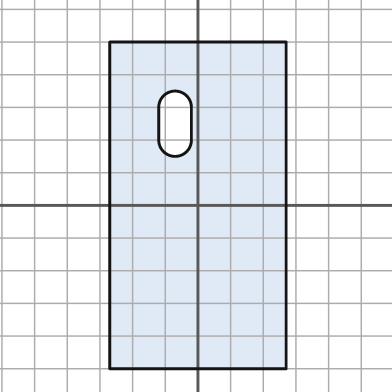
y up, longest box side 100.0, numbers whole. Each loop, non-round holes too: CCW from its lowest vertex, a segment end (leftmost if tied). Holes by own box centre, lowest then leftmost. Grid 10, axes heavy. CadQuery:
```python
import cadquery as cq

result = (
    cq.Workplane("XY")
    .moveTo(-27.0, -50.0)
    .lineTo(27.0, -50.0)
    .lineTo(27.0, 50.0)
    .lineTo(-27.0, 50.0)
    .close()
    .moveTo(-12.0, 20.0)
    .threePointArc((-7.0, 15.0), (-2.0, 20.0))
    .lineTo(-2.0, 30.0)
    .threePointArc((-7.0, 35.0), (-12.0, 30.0))
    .close()
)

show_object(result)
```